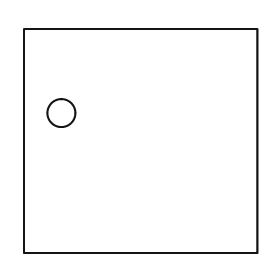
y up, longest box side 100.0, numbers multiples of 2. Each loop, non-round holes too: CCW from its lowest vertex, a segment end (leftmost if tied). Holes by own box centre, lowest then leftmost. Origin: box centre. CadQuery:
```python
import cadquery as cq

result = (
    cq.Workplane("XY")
    .moveTo(-50.0, -48.0)
    .lineTo(50.0, -48.0)
    .lineTo(50.0, 48.0)
    .lineTo(-50.0, 48.0)
    .close()
    .moveTo(-34.0, 12.0)
    .circle(6.0)
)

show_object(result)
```